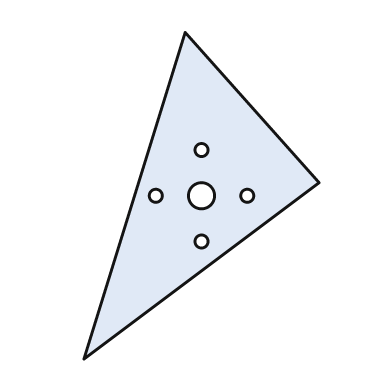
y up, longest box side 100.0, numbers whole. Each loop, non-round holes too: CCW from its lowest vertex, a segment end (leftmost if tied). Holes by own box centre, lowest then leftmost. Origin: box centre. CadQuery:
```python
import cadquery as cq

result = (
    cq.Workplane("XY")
    .moveTo(-36.0, -50.0)
    .lineTo(36.0, 4.0)
    .lineTo(-5.0, 50.0)
    .close()
    .moveTo(0.0, -14.0)
    .circle(2.0)
    .moveTo(-14.0, 0.0)
    .circle(2.0)
    .moveTo(0.0, 0.0)
    .circle(4.0)
    .moveTo(14.0, 0.0)
    .circle(2.0)
    .moveTo(0.0, 14.0)
    .circle(2.0)
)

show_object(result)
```